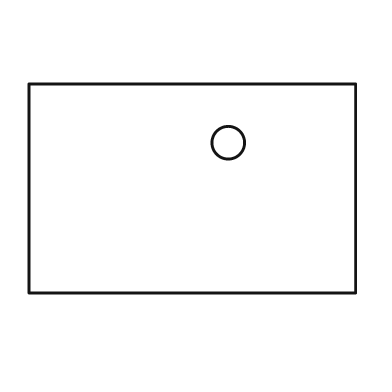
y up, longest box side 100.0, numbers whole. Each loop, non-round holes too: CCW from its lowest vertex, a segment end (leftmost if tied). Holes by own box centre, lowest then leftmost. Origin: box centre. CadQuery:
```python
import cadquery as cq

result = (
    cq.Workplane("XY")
    .moveTo(-50.0, -32.0)
    .lineTo(50.0, -32.0)
    .lineTo(50.0, 32.0)
    .lineTo(-50.0, 32.0)
    .close()
    .moveTo(11.0, 14.0)
    .circle(5.0)
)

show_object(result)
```